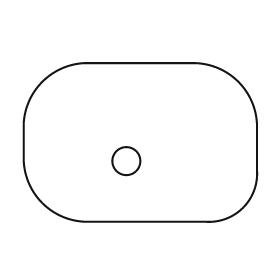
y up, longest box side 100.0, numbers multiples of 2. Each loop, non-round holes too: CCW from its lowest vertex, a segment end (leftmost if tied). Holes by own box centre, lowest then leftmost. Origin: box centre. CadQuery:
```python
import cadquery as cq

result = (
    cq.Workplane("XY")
    .moveTo(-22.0, -34.0)
    .lineTo(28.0, -34.0)
    .threePointArc((44.0, -28.0), (50.0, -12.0))
    .lineTo(50.0, 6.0)
    .threePointArc((42.0, 26.0), (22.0, 34.0))
    .lineTo(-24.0, 34.0)
    .threePointArc((-42.0, 26.0), (-50.0, 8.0))
    .lineTo(-50.0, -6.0)
    .threePointArc((-42.0, -26.0), (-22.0, -34.0))
    .close()
    .moveTo(-6.0, -8.0)
    .circle(6.0)
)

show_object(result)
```